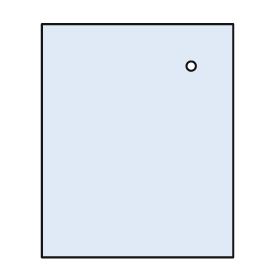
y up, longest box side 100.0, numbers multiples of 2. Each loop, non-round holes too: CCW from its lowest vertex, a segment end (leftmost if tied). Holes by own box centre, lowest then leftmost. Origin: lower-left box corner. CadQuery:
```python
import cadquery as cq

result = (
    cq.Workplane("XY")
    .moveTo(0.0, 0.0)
    .lineTo(82.0, 0.0)
    .lineTo(82.0, 100.0)
    .lineTo(0.0, 100.0)
    .close()
    .moveTo(64.0, 82.0)
    .circle(2.0)
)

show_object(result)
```